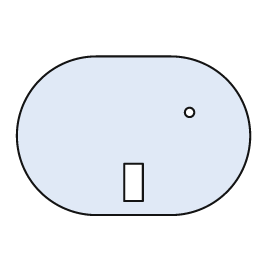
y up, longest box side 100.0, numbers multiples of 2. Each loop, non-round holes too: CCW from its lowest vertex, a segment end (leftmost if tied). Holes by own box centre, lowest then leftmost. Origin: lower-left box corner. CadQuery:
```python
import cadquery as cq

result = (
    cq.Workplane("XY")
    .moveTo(34.0, 0.0)
    .lineTo(66.0, 0.0)
    .threePointArc((100.0, 34.0), (66.0, 68.0))
    .lineTo(34.0, 68.0)
    .threePointArc((0.0, 34.0), (34.0, 0.0))
    .close()
    .moveTo(46.0, 6.0)
    .lineTo(54.0, 6.0)
    .lineTo(54.0, 22.0)
    .lineTo(46.0, 22.0)
    .close()
    .moveTo(74.0, 44.0)
    .circle(2.0)
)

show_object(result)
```